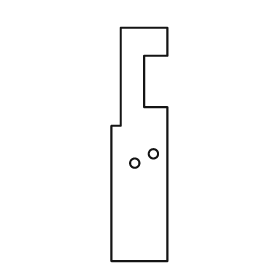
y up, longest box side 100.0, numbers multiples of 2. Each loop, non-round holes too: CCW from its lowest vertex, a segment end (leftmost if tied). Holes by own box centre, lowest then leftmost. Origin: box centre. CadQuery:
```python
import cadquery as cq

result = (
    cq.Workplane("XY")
    .moveTo(-12.0, -50.0)
    .lineTo(12.0, -50.0)
    .lineTo(12.0, 16.0)
    .lineTo(2.0, 16.0)
    .lineTo(2.0, 38.0)
    .lineTo(12.0, 38.0)
    .lineTo(12.0, 50.0)
    .lineTo(-8.0, 50.0)
    .lineTo(-8.0, 8.0)
    .lineTo(-12.0, 8.0)
    .close()
    .moveTo(-2.0, -8.0)
    .circle(2.0)
    .moveTo(6.0, -4.0)
    .circle(2.0)
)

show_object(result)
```